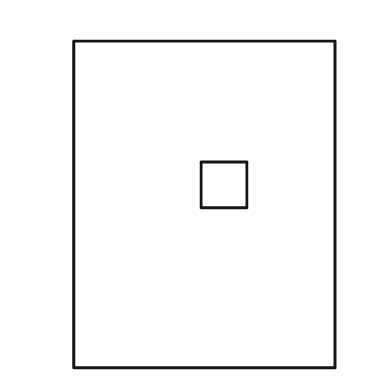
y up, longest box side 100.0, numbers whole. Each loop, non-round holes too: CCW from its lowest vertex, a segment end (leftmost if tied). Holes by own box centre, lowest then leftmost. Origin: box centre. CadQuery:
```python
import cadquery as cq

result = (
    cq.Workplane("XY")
    .moveTo(-40.0, -50.0)
    .lineTo(40.0, -50.0)
    .lineTo(40.0, 50.0)
    .lineTo(-40.0, 50.0)
    .close()
    .moveTo(-1.0, -1.0)
    .lineTo(13.0, -1.0)
    .lineTo(13.0, 13.0)
    .lineTo(-1.0, 13.0)
    .close()
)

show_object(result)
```